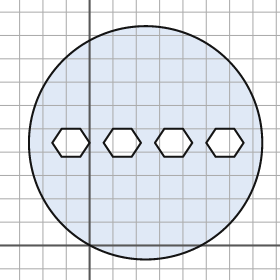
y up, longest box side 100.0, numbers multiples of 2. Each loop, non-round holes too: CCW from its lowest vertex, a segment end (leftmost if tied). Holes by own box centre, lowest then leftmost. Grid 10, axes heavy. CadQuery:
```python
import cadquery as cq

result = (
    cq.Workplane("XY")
    .moveTo(24.0, 44.0)
    .circle(50.0)
    .moveTo(-12.0, 38.0)
    .lineTo(-4.0, 38.0)
    .lineTo(0.0, 44.0)
    .lineTo(-4.0, 50.0)
    .lineTo(-12.0, 50.0)
    .lineTo(-16.0, 44.0)
    .close()
    .moveTo(10.0, 38.0)
    .lineTo(18.0, 38.0)
    .lineTo(22.0, 44.0)
    .lineTo(18.0, 50.0)
    .lineTo(10.0, 50.0)
    .lineTo(6.0, 44.0)
    .close()
    .moveTo(32.0, 38.0)
    .lineTo(40.0, 38.0)
    .lineTo(44.0, 44.0)
    .lineTo(40.0, 50.0)
    .lineTo(32.0, 50.0)
    .lineTo(28.0, 44.0)
    .close()
    .moveTo(54.0, 38.0)
    .lineTo(62.0, 38.0)
    .lineTo(66.0, 44.0)
    .lineTo(62.0, 50.0)
    .lineTo(54.0, 50.0)
    .lineTo(50.0, 44.0)
    .close()
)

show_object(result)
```